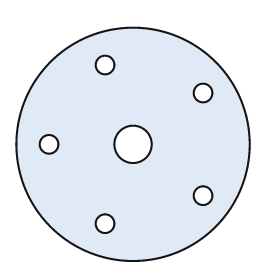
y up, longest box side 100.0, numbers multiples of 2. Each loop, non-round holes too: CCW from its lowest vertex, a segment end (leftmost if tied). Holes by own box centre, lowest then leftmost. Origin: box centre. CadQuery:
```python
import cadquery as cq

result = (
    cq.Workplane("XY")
    .moveTo(0.0, 0.0)
    .circle(50.0)
    .moveTo(-12.0, -34.0)
    .circle(4.0)
    .moveTo(30.0, -22.0)
    .circle(4.0)
    .moveTo(-36.0, 0.0)
    .circle(4.0)
    .moveTo(0.0, 0.0)
    .circle(8.0)
    .moveTo(30.0, 22.0)
    .circle(4.0)
    .moveTo(-12.0, 34.0)
    .circle(4.0)
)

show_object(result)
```